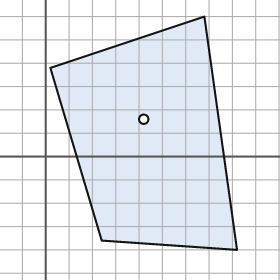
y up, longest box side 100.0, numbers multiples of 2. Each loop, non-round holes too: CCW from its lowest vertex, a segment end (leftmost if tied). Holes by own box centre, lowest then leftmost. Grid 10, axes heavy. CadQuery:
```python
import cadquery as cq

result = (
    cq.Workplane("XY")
    .moveTo(82.0, -40.0)
    .lineTo(68.0, 60.0)
    .lineTo(2.0, 38.0)
    .lineTo(24.0, -36.0)
    .close()
    .moveTo(42.0, 16.0)
    .circle(2.0)
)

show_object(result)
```